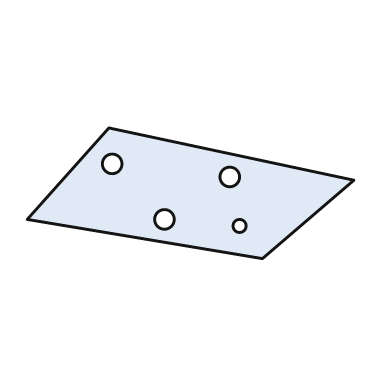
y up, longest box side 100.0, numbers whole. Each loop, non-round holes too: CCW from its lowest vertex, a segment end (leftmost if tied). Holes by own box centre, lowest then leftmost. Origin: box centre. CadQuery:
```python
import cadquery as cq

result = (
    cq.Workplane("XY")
    .moveTo(22.0, -20.0)
    .lineTo(50.0, 4.0)
    .lineTo(-25.0, 20.0)
    .lineTo(-50.0, -8.0)
    .close()
    .moveTo(15.0, -10.0)
    .circle(2.0)
    .moveTo(-8.0, -8.0)
    .circle(3.0)
    .moveTo(12.0, 5.0)
    .circle(3.0)
    .moveTo(-24.0, 9.0)
    .circle(3.0)
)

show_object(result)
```